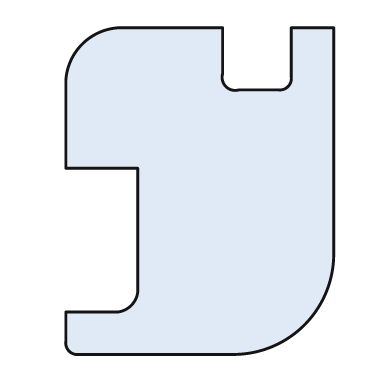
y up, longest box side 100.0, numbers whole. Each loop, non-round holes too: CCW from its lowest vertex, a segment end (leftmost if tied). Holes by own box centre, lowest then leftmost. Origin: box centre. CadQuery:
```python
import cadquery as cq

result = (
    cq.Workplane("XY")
    .moveTo(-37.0, -50.0)
    .lineTo(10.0, -50.0)
    .threePointArc((32.0, -41.0), (41.0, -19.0))
    .lineTo(41.0, 50.0)
    .lineTo(28.0, 50.0)
    .lineTo(28.0, 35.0)
    .threePointArc((27.0, 32.0), (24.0, 31.0))
    .lineTo(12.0, 31.0)
    .threePointArc((8.0, 32.0), (7.0, 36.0))
    .lineTo(7.0, 50.0)
    .lineTo(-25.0, 50.0)
    .threePointArc((-36.0, 45.0), (-41.0, 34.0))
    .lineTo(-41.0, 7.0)
    .lineTo(-19.0, 7.0)
    .lineTo(-19.0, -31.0)
    .threePointArc((-21.0, -35.0), (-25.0, -37.0))
    .lineTo(-41.0, -37.0)
    .lineTo(-41.0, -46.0)
    .threePointArc((-40.0, -49.0), (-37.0, -50.0))
    .close()
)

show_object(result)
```